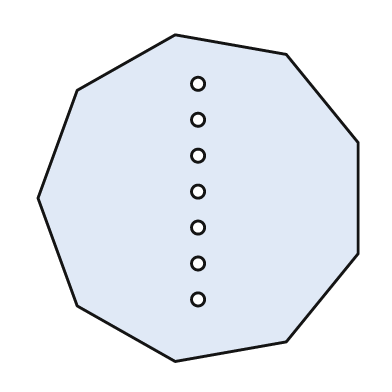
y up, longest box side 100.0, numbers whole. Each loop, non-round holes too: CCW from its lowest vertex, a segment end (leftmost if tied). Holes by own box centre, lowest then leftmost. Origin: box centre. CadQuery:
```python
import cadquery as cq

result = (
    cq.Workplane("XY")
    .moveTo(-7.0, -50.0)
    .lineTo(27.0, -44.0)
    .lineTo(49.0, -17.0)
    .lineTo(49.0, 17.0)
    .lineTo(27.0, 44.0)
    .lineTo(-7.0, 50.0)
    .lineTo(-37.0, 33.0)
    .lineTo(-49.0, 0.0)
    .lineTo(-37.0, -33.0)
    .close()
    .moveTo(0.0, -31.0)
    .circle(2.0)
    .moveTo(0.0, -20.0)
    .circle(2.0)
    .moveTo(0.0, -9.0)
    .circle(2.0)
    .moveTo(0.0, 2.0)
    .circle(2.0)
    .moveTo(0.0, 13.0)
    .circle(2.0)
    .moveTo(0.0, 24.0)
    .circle(2.0)
    .moveTo(0.0, 35.0)
    .circle(2.0)
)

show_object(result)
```